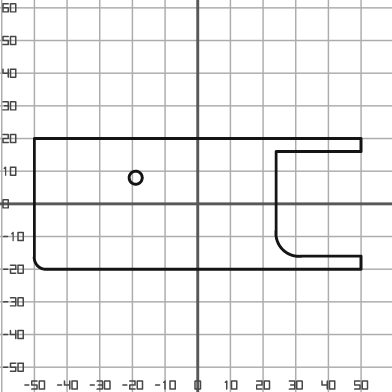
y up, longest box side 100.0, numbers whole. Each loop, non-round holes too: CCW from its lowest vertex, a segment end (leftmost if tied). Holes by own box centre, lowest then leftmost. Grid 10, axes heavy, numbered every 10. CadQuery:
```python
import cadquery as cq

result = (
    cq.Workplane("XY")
    .moveTo(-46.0, -20.0)
    .lineTo(50.0, -20.0)
    .lineTo(50.0, -16.0)
    .lineTo(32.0, -16.0)
    .threePointArc((26.0, -14.0), (24.0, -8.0))
    .lineTo(24.0, 16.0)
    .lineTo(50.0, 16.0)
    .lineTo(50.0, 20.0)
    .lineTo(-50.0, 20.0)
    .lineTo(-50.0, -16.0)
    .threePointArc((-49.0, -19.0), (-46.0, -20.0))
    .close()
    .moveTo(-19.0, 8.0)
    .circle(2.0)
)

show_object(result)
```